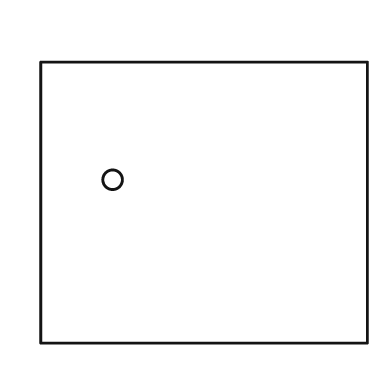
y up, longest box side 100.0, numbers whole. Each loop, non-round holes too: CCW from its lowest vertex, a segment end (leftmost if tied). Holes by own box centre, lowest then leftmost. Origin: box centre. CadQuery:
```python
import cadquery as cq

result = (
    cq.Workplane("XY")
    .moveTo(-50.0, -43.0)
    .lineTo(50.0, -43.0)
    .lineTo(50.0, 43.0)
    .lineTo(-50.0, 43.0)
    .close()
    .moveTo(-28.0, 7.0)
    .circle(3.0)
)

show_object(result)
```